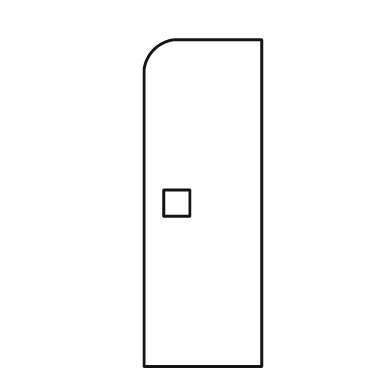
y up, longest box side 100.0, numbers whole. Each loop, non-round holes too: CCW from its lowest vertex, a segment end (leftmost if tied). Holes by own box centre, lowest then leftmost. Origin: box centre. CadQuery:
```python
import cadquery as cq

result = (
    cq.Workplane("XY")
    .moveTo(-18.0, -50.0)
    .lineTo(18.0, -50.0)
    .lineTo(18.0, 50.0)
    .lineTo(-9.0, 50.0)
    .threePointArc((-15.0, 47.0), (-18.0, 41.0))
    .close()
    .moveTo(-12.0, -4.0)
    .lineTo(-4.0, -4.0)
    .lineTo(-4.0, 4.0)
    .lineTo(-12.0, 4.0)
    .close()
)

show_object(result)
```